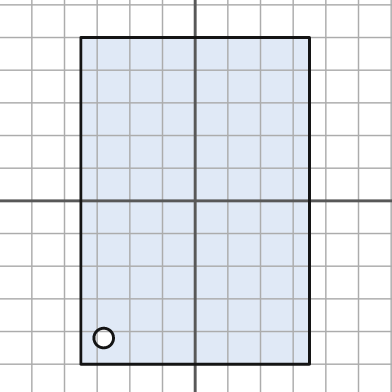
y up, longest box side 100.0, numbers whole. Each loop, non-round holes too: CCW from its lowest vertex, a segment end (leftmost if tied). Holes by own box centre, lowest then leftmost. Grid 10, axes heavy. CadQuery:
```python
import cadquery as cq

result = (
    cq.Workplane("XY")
    .moveTo(-35.0, -50.0)
    .lineTo(35.0, -50.0)
    .lineTo(35.0, 50.0)
    .lineTo(-35.0, 50.0)
    .close()
    .moveTo(-28.0, -42.0)
    .circle(3.0)
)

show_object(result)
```